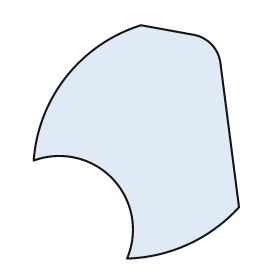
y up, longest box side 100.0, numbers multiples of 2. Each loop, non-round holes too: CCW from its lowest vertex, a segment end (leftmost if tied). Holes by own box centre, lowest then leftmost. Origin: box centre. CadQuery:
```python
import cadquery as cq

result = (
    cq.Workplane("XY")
    .moveTo(-4.0, -50.0)
    .threePointArc((22.0, -44.0), (44.0, -28.0))
    .lineTo(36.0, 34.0)
    .threePointArc((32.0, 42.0), (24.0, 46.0))
    .lineTo(2.0, 50.0)
    .threePointArc((-30.0, 28.0), (-44.0, -8.0))
    .threePointArc((-10.0, -16.0), (-4.0, -50.0))
    .close()
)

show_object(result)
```